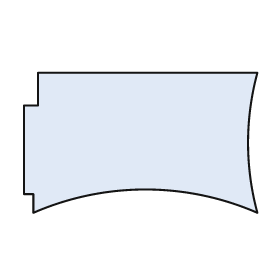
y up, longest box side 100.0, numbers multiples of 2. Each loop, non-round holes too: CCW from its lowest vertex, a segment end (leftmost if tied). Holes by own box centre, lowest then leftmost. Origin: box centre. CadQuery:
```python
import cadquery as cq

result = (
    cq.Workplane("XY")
    .moveTo(-46.0, -30.0)
    .threePointArc((2.0, -20.0), (50.0, -30.0))
    .threePointArc((46.0, 0.0), (50.0, 30.0))
    .lineTo(-44.0, 30.0)
    .lineTo(-44.0, 16.0)
    .lineTo(-50.0, 16.0)
    .lineTo(-50.0, -22.0)
    .lineTo(-46.0, -22.0)
    .close()
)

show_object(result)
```